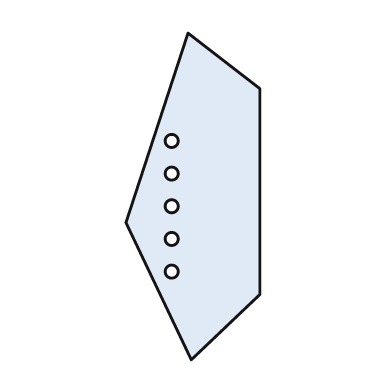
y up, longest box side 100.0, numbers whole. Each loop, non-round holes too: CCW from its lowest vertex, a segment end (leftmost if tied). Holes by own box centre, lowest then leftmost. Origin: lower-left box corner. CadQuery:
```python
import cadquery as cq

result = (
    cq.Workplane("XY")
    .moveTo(20.0, 0.0)
    .lineTo(41.0, 20.0)
    .lineTo(41.0, 83.0)
    .lineTo(19.0, 100.0)
    .lineTo(0.0, 42.0)
    .close()
    .moveTo(14.0, 27.0)
    .circle(2.0)
    .moveTo(14.0, 37.0)
    .circle(2.0)
    .moveTo(14.0, 47.0)
    .circle(2.0)
    .moveTo(14.0, 57.0)
    .circle(2.0)
    .moveTo(14.0, 67.0)
    .circle(2.0)
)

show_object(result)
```